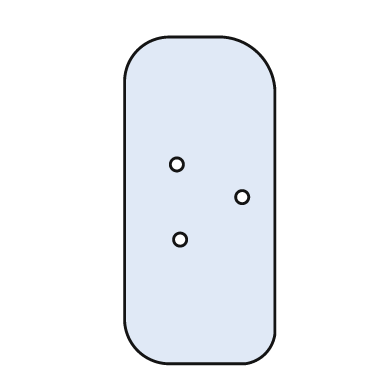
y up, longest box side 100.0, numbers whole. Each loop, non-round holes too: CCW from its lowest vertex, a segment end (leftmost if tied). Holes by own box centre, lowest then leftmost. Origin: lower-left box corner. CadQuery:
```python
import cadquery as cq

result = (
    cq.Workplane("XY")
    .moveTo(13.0, 0.0)
    .lineTo(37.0, 0.0)
    .threePointArc((43.0, 3.0), (46.0, 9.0))
    .lineTo(46.0, 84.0)
    .threePointArc((41.0, 95.0), (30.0, 100.0))
    .lineTo(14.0, 100.0)
    .threePointArc((4.0, 96.0), (0.0, 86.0))
    .lineTo(0.0, 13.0)
    .threePointArc((4.0, 4.0), (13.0, 0.0))
    .close()
    .moveTo(17.0, 38.0)
    .circle(2.0)
    .moveTo(36.0, 51.0)
    .circle(2.0)
    .moveTo(16.0, 61.0)
    .circle(2.0)
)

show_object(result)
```